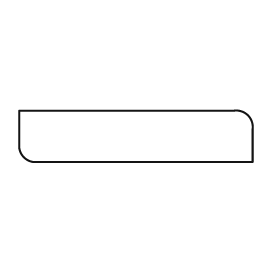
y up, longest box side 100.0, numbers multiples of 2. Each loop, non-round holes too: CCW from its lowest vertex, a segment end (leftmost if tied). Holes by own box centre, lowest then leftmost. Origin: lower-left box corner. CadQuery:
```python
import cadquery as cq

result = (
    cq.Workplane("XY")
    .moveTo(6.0, 0.0)
    .lineTo(100.0, 0.0)
    .lineTo(100.0, 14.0)
    .threePointArc((98.0, 20.0), (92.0, 22.0))
    .lineTo(0.0, 22.0)
    .lineTo(0.0, 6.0)
    .threePointArc((2.0, 2.0), (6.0, 0.0))
    .close()
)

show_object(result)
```